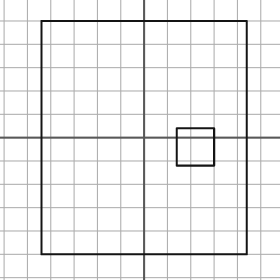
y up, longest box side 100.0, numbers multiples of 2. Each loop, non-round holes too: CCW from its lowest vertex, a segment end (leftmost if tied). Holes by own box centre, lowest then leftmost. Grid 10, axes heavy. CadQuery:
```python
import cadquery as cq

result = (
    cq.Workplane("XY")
    .moveTo(-44.0, -50.0)
    .lineTo(44.0, -50.0)
    .lineTo(44.0, 50.0)
    .lineTo(-44.0, 50.0)
    .close()
    .moveTo(14.0, -12.0)
    .lineTo(30.0, -12.0)
    .lineTo(30.0, 4.0)
    .lineTo(14.0, 4.0)
    .close()
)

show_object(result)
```